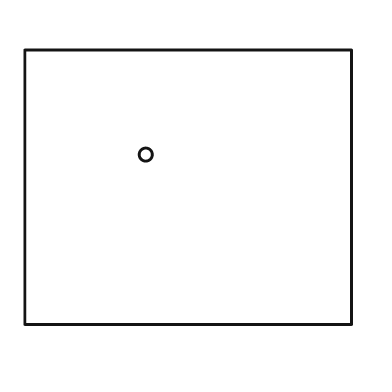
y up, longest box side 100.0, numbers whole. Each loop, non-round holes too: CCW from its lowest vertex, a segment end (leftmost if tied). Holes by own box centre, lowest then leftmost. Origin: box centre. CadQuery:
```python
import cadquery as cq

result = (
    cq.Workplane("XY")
    .moveTo(-50.0, -42.0)
    .lineTo(50.0, -42.0)
    .lineTo(50.0, 42.0)
    .lineTo(-50.0, 42.0)
    .close()
    .moveTo(-13.0, 10.0)
    .circle(2.0)
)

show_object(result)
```